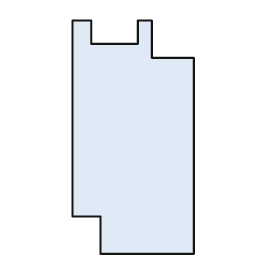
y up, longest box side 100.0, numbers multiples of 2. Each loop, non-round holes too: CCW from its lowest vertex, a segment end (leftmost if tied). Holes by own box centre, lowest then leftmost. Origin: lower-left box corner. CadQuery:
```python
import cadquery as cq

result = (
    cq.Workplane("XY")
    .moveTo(12.0, 0.0)
    .lineTo(52.0, 0.0)
    .lineTo(52.0, 84.0)
    .lineTo(34.0, 84.0)
    .lineTo(34.0, 100.0)
    .lineTo(28.0, 100.0)
    .lineTo(28.0, 90.0)
    .lineTo(8.0, 90.0)
    .lineTo(8.0, 100.0)
    .lineTo(0.0, 100.0)
    .lineTo(0.0, 16.0)
    .lineTo(12.0, 16.0)
    .close()
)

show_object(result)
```